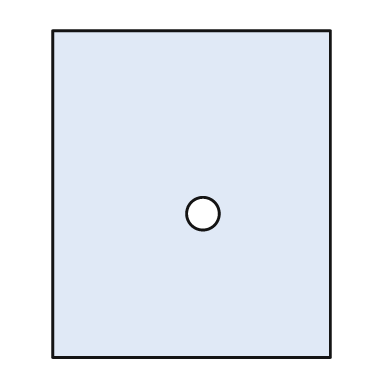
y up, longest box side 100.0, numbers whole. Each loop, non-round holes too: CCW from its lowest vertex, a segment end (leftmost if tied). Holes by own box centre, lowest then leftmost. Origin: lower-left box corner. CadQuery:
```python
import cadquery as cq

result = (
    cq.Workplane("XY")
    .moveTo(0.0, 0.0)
    .lineTo(85.0, 0.0)
    .lineTo(85.0, 100.0)
    .lineTo(0.0, 100.0)
    .close()
    .moveTo(46.0, 44.0)
    .circle(5.0)
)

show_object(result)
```